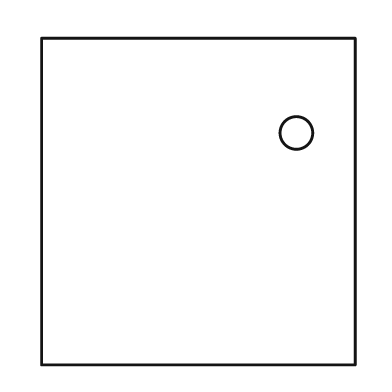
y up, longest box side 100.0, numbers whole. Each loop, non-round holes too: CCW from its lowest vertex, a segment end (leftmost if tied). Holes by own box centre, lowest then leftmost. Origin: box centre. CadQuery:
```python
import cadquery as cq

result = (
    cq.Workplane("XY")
    .moveTo(-48.0, -50.0)
    .lineTo(48.0, -50.0)
    .lineTo(48.0, 50.0)
    .lineTo(-48.0, 50.0)
    .close()
    .moveTo(30.0, 21.0)
    .circle(5.0)
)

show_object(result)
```